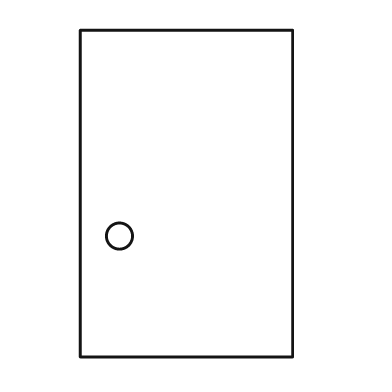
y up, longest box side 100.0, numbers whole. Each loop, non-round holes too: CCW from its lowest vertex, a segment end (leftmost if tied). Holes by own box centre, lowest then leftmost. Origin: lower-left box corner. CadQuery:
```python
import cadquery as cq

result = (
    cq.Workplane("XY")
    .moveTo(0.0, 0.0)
    .lineTo(65.0, 0.0)
    .lineTo(65.0, 100.0)
    .lineTo(0.0, 100.0)
    .close()
    .moveTo(12.0, 37.0)
    .circle(4.0)
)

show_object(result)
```